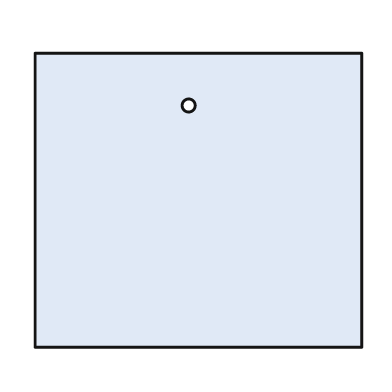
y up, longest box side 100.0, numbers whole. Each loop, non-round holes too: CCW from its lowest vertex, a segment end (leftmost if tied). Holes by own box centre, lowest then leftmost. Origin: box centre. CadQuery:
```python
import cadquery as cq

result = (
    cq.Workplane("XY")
    .moveTo(-50.0, -45.0)
    .lineTo(50.0, -45.0)
    .lineTo(50.0, 45.0)
    .lineTo(-50.0, 45.0)
    .close()
    .moveTo(-3.0, 29.0)
    .circle(2.0)
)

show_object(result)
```